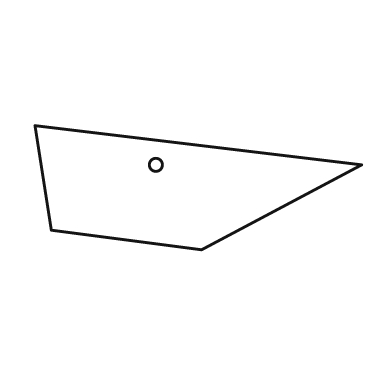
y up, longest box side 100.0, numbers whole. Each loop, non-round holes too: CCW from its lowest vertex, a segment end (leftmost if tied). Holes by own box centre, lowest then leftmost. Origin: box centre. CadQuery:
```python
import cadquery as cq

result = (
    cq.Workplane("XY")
    .moveTo(1.0, -19.0)
    .lineTo(50.0, 7.0)
    .lineTo(-50.0, 19.0)
    .lineTo(-45.0, -13.0)
    .close()
    .moveTo(-13.0, 7.0)
    .circle(2.0)
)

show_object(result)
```